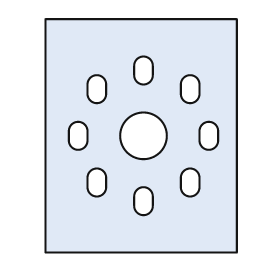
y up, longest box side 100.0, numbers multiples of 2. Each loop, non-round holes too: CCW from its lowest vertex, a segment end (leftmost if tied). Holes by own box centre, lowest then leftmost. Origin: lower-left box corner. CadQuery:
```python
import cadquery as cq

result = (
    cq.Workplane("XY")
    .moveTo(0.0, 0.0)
    .lineTo(82.0, 0.0)
    .lineTo(82.0, 100.0)
    .lineTo(0.0, 100.0)
    .close()
    .moveTo(38.0, 20.0)
    .threePointArc((42.0, 16.0), (46.0, 20.0))
    .lineTo(46.0, 24.0)
    .threePointArc((42.0, 28.0), (38.0, 24.0))
    .close()
    .moveTo(18.0, 28.0)
    .threePointArc((22.0, 24.0), (26.0, 28.0))
    .lineTo(26.0, 32.0)
    .threePointArc((22.0, 36.0), (18.0, 32.0))
    .close()
    .moveTo(58.0, 28.0)
    .threePointArc((62.0, 24.0), (66.0, 28.0))
    .lineTo(66.0, 32.0)
    .threePointArc((62.0, 36.0), (58.0, 32.0))
    .close()
    .moveTo(10.0, 48.0)
    .threePointArc((14.0, 44.0), (18.0, 48.0))
    .lineTo(18.0, 52.0)
    .threePointArc((14.0, 56.0), (10.0, 52.0))
    .close()
    .moveTo(42.0, 50.0)
    .circle(10.0)
    .moveTo(66.0, 48.0)
    .threePointArc((70.0, 44.0), (74.0, 48.0))
    .lineTo(74.0, 52.0)
    .threePointArc((70.0, 56.0), (66.0, 52.0))
    .close()
    .moveTo(18.0, 68.0)
    .threePointArc((22.0, 64.0), (26.0, 68.0))
    .lineTo(26.0, 72.0)
    .threePointArc((22.0, 76.0), (18.0, 72.0))
    .close()
    .moveTo(58.0, 68.0)
    .threePointArc((62.0, 64.0), (66.0, 68.0))
    .lineTo(66.0, 72.0)
    .threePointArc((62.0, 76.0), (58.0, 72.0))
    .close()
    .moveTo(38.0, 76.0)
    .threePointArc((42.0, 72.0), (46.0, 76.0))
    .lineTo(46.0, 80.0)
    .threePointArc((42.0, 84.0), (38.0, 80.0))
    .close()
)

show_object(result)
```